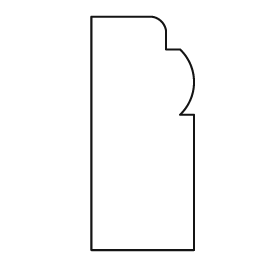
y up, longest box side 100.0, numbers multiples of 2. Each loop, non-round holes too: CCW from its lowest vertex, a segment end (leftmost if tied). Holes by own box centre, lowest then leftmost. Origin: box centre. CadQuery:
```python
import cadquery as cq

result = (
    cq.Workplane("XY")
    .moveTo(-22.0, -50.0)
    .lineTo(22.0, -50.0)
    .lineTo(22.0, 8.0)
    .lineTo(16.0, 8.0)
    .threePointArc((22.0, 22.0), (16.0, 36.0))
    .lineTo(10.0, 36.0)
    .lineTo(10.0, 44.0)
    .threePointArc((8.0, 48.0), (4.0, 50.0))
    .lineTo(-22.0, 50.0)
    .close()
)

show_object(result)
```